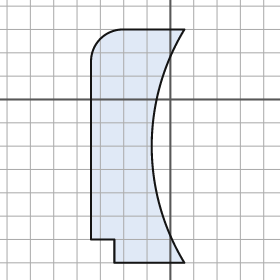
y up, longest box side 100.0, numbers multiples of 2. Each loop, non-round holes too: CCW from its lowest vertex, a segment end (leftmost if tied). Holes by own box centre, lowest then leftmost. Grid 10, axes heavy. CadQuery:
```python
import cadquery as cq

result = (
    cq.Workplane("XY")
    .moveTo(-24.0, -70.0)
    .lineTo(6.0, -70.0)
    .threePointArc((-8.0, -20.0), (6.0, 30.0))
    .lineTo(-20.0, 30.0)
    .threePointArc((-30.0, 26.0), (-34.0, 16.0))
    .lineTo(-34.0, -60.0)
    .lineTo(-24.0, -60.0)
    .close()
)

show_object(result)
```